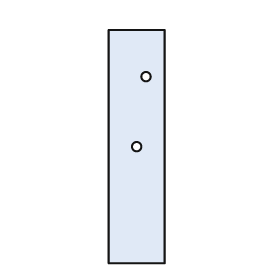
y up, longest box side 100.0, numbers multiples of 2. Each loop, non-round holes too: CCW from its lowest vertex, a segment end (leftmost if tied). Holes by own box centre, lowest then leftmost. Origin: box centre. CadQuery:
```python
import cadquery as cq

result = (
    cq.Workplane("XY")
    .moveTo(-12.0, -50.0)
    .lineTo(12.0, -50.0)
    .lineTo(12.0, 50.0)
    .lineTo(-12.0, 50.0)
    .close()
    .moveTo(0.0, 0.0)
    .circle(2.0)
    .moveTo(4.0, 30.0)
    .circle(2.0)
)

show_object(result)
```